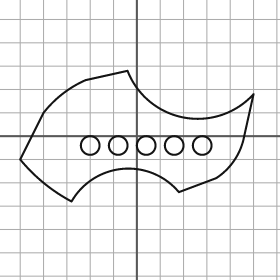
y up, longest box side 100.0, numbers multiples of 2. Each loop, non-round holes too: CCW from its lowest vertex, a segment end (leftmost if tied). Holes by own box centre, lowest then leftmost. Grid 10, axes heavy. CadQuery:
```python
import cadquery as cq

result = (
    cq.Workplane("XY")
    .moveTo(-28.0, -28.0)
    .threePointArc((-6.0, -14.0), (18.0, -24.0))
    .lineTo(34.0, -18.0)
    .threePointArc((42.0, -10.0), (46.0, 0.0))
    .lineTo(50.0, 18.0)
    .threePointArc((20.0, 8.0), (-4.0, 28.0))
    .lineTo(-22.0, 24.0)
    .threePointArc((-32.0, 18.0), (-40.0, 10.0))
    .lineTo(-50.0, -10.0)
    .threePointArc((-40.0, -20.0), (-28.0, -28.0))
    .close()
    .moveTo(-20.0, -4.0)
    .circle(4.0)
    .moveTo(-8.0, -4.0)
    .circle(4.0)
    .moveTo(4.0, -4.0)
    .circle(4.0)
    .moveTo(16.0, -4.0)
    .circle(4.0)
    .moveTo(28.0, -4.0)
    .circle(4.0)
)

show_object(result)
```